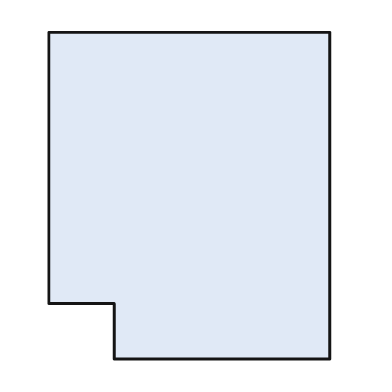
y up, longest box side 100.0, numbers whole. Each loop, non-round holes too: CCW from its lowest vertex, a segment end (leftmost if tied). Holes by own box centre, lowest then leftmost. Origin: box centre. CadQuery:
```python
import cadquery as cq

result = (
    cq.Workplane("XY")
    .moveTo(-23.0, -50.0)
    .lineTo(43.0, -50.0)
    .lineTo(43.0, 50.0)
    .lineTo(-43.0, 50.0)
    .lineTo(-43.0, -33.0)
    .lineTo(-23.0, -33.0)
    .close()
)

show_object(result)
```